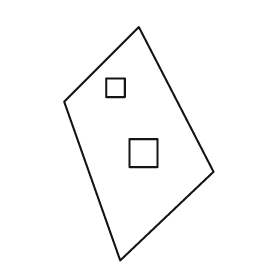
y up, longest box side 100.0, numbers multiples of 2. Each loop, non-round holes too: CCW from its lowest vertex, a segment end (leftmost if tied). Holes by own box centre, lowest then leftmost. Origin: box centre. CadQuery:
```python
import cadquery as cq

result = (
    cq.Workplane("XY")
    .moveTo(-8.0, -50.0)
    .lineTo(32.0, -12.0)
    .lineTo(0.0, 50.0)
    .lineTo(-32.0, 18.0)
    .close()
    .moveTo(-4.0, -10.0)
    .lineTo(8.0, -10.0)
    .lineTo(8.0, 2.0)
    .lineTo(-4.0, 2.0)
    .close()
    .moveTo(-14.0, 20.0)
    .lineTo(-6.0, 20.0)
    .lineTo(-6.0, 28.0)
    .lineTo(-14.0, 28.0)
    .close()
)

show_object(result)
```